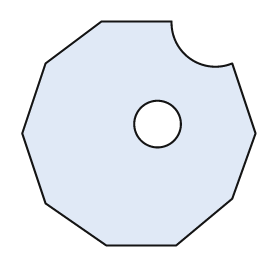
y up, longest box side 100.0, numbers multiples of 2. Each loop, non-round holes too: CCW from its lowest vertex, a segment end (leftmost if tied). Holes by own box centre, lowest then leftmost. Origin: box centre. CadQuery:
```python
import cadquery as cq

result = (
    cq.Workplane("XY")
    .moveTo(-14.0, -48.0)
    .lineTo(16.0, -48.0)
    .lineTo(40.0, -28.0)
    .lineTo(50.0, 0.0)
    .lineTo(40.0, 30.0)
    .threePointArc((22.0, 32.0), (14.0, 48.0))
    .lineTo(-16.0, 48.0)
    .lineTo(-40.0, 30.0)
    .lineTo(-50.0, 0.0)
    .lineTo(-40.0, -30.0)
    .close()
    .moveTo(8.0, 4.0)
    .circle(10.0)
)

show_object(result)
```